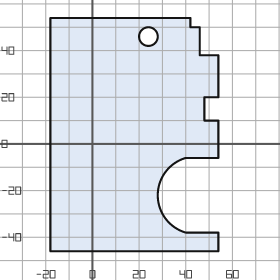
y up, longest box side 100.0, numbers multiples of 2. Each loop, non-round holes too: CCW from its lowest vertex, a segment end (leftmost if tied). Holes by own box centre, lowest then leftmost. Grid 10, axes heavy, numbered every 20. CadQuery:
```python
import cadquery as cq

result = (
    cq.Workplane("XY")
    .moveTo(-18.0, -46.0)
    .lineTo(54.0, -46.0)
    .lineTo(54.0, -38.0)
    .lineTo(40.0, -38.0)
    .threePointArc((28.0, -22.0), (40.0, -6.0))
    .lineTo(54.0, -6.0)
    .lineTo(54.0, 10.0)
    .lineTo(48.0, 10.0)
    .lineTo(48.0, 20.0)
    .lineTo(54.0, 20.0)
    .lineTo(54.0, 38.0)
    .lineTo(46.0, 38.0)
    .lineTo(46.0, 50.0)
    .lineTo(42.0, 50.0)
    .lineTo(42.0, 54.0)
    .lineTo(-18.0, 54.0)
    .close()
    .moveTo(24.0, 46.0)
    .circle(4.0)
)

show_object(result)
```